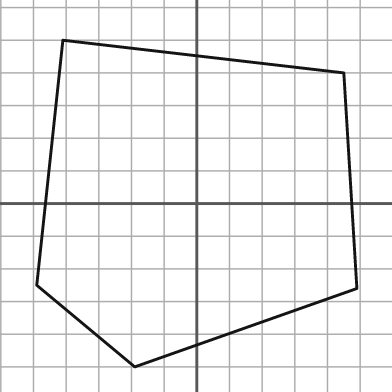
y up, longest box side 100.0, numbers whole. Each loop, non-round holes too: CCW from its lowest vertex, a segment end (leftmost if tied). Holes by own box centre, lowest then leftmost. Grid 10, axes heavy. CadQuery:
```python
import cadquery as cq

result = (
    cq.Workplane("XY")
    .moveTo(-19.0, -50.0)
    .lineTo(49.0, -26.0)
    .lineTo(45.0, 40.0)
    .lineTo(-41.0, 50.0)
    .lineTo(-49.0, -25.0)
    .close()
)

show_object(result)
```